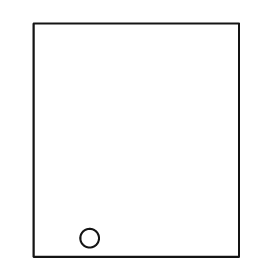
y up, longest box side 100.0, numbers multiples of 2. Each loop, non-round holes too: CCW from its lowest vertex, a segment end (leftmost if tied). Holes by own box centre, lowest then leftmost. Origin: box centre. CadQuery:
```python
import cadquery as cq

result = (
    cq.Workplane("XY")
    .moveTo(-44.0, -50.0)
    .lineTo(44.0, -50.0)
    .lineTo(44.0, 50.0)
    .lineTo(-44.0, 50.0)
    .close()
    .moveTo(-20.0, -42.0)
    .circle(4.0)
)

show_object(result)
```